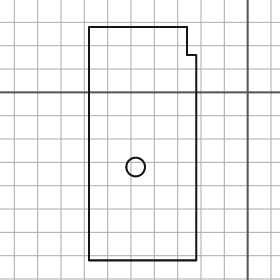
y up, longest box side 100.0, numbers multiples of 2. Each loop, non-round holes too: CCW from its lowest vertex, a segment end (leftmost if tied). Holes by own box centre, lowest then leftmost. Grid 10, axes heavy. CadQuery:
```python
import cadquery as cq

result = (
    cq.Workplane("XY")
    .moveTo(-68.0, -72.0)
    .lineTo(-22.0, -72.0)
    .lineTo(-22.0, 16.0)
    .lineTo(-26.0, 16.0)
    .lineTo(-26.0, 28.0)
    .lineTo(-68.0, 28.0)
    .close()
    .moveTo(-48.0, -32.0)
    .circle(4.0)
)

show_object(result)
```